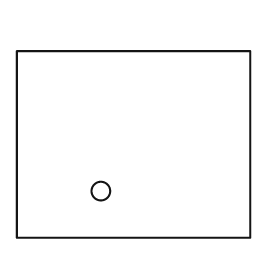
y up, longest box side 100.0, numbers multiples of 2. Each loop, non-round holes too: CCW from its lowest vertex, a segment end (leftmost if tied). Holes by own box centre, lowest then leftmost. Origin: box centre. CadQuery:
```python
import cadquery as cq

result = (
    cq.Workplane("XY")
    .moveTo(-50.0, -40.0)
    .lineTo(50.0, -40.0)
    .lineTo(50.0, 40.0)
    .lineTo(-50.0, 40.0)
    .close()
    .moveTo(-14.0, -20.0)
    .circle(4.0)
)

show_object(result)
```